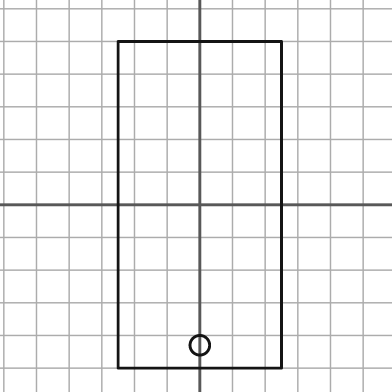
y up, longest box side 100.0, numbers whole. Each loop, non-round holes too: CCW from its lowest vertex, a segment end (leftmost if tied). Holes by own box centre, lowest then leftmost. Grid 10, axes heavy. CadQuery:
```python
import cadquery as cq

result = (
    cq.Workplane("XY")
    .moveTo(-25.0, -50.0)
    .lineTo(25.0, -50.0)
    .lineTo(25.0, 50.0)
    .lineTo(-25.0, 50.0)
    .close()
    .moveTo(0.0, -43.0)
    .circle(3.0)
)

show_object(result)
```